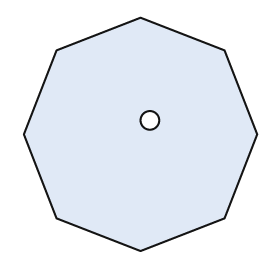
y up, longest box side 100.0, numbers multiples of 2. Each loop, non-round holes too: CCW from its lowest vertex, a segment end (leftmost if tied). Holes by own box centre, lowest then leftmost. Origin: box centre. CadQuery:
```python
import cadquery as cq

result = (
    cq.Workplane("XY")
    .moveTo(0.0, -50.0)
    .lineTo(36.0, -36.0)
    .lineTo(50.0, 0.0)
    .lineTo(36.0, 36.0)
    .lineTo(0.0, 50.0)
    .lineTo(-36.0, 36.0)
    .lineTo(-50.0, 0.0)
    .lineTo(-36.0, -36.0)
    .close()
    .moveTo(4.0, 6.0)
    .circle(4.0)
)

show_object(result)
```